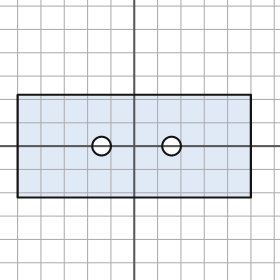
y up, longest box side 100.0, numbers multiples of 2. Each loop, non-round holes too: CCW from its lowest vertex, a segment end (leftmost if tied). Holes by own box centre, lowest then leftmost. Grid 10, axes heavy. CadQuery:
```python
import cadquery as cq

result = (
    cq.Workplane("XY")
    .moveTo(-50.0, -22.0)
    .lineTo(50.0, -22.0)
    .lineTo(50.0, 22.0)
    .lineTo(-50.0, 22.0)
    .close()
    .moveTo(-14.0, 0.0)
    .circle(4.0)
    .moveTo(16.0, 0.0)
    .circle(4.0)
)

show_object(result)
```